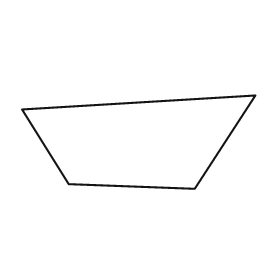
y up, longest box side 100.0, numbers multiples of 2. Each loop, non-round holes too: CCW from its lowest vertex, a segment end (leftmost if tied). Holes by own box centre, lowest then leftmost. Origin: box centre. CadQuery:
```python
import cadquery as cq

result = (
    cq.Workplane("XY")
    .moveTo(24.0, -20.0)
    .lineTo(50.0, 20.0)
    .lineTo(-50.0, 14.0)
    .lineTo(-30.0, -18.0)
    .close()
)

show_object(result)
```